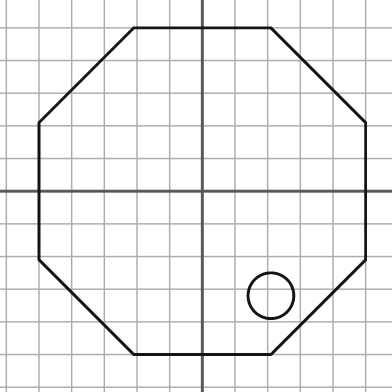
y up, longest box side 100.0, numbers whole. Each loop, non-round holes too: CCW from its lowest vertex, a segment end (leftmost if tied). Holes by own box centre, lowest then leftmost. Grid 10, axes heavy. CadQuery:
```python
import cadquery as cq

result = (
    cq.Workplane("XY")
    .moveTo(-21.0, -50.0)
    .lineTo(21.0, -50.0)
    .lineTo(50.0, -21.0)
    .lineTo(50.0, 21.0)
    .lineTo(21.0, 50.0)
    .lineTo(-21.0, 50.0)
    .lineTo(-50.0, 21.0)
    .lineTo(-50.0, -21.0)
    .close()
    .moveTo(21.0, -32.0)
    .circle(7.0)
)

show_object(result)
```